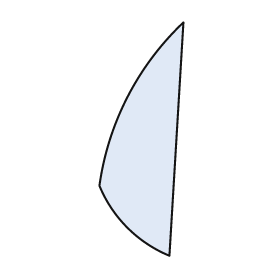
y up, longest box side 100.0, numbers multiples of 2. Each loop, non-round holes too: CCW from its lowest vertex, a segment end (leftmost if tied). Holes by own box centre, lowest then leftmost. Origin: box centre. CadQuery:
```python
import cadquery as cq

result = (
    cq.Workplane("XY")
    .moveTo(12.0, -50.0)
    .lineTo(18.0, 50.0)
    .threePointArc((-6.0, 18.0), (-18.0, -20.0))
    .threePointArc((-6.0, -38.0), (12.0, -50.0))
    .close()
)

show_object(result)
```